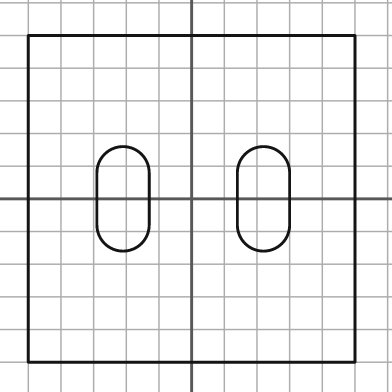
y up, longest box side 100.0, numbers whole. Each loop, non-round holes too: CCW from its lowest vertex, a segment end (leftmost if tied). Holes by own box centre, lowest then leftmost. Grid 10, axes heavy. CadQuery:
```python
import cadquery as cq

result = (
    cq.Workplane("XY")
    .moveTo(-50.0, -50.0)
    .lineTo(50.0, -50.0)
    .lineTo(50.0, 50.0)
    .lineTo(-50.0, 50.0)
    .close()
    .moveTo(-29.0, -8.0)
    .threePointArc((-21.0, -16.0), (-13.0, -8.0))
    .lineTo(-13.0, 8.0)
    .threePointArc((-21.0, 16.0), (-29.0, 8.0))
    .close()
    .moveTo(14.0, -8.0)
    .threePointArc((22.0, -16.0), (30.0, -8.0))
    .lineTo(30.0, 8.0)
    .threePointArc((22.0, 16.0), (14.0, 8.0))
    .close()
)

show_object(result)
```